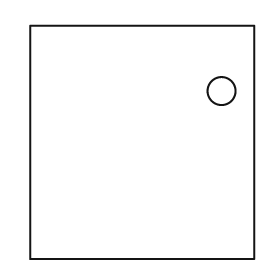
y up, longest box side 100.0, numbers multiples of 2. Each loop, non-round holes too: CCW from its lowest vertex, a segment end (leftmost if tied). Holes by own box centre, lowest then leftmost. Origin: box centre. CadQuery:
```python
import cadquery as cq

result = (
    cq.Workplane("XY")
    .moveTo(-48.0, -50.0)
    .lineTo(48.0, -50.0)
    .lineTo(48.0, 50.0)
    .lineTo(-48.0, 50.0)
    .close()
    .moveTo(34.0, 22.0)
    .circle(6.0)
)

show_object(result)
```